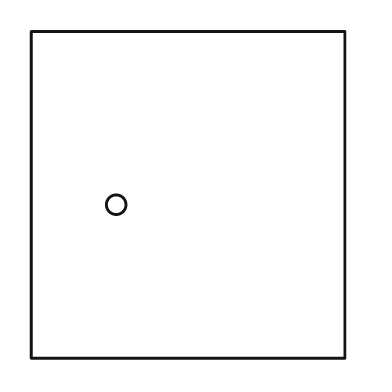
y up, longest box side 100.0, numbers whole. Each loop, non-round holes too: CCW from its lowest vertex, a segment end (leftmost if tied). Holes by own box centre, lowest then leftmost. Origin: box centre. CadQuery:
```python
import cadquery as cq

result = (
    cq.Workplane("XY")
    .moveTo(-48.0, -50.0)
    .lineTo(48.0, -50.0)
    .lineTo(48.0, 50.0)
    .lineTo(-48.0, 50.0)
    .close()
    .moveTo(-22.0, -3.0)
    .circle(3.0)
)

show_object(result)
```